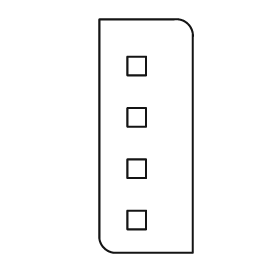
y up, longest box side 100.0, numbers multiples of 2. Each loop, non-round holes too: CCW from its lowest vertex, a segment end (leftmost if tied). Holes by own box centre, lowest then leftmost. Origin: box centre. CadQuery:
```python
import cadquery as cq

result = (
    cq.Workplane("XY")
    .moveTo(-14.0, -50.0)
    .lineTo(20.0, -50.0)
    .lineTo(20.0, 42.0)
    .threePointArc((18.0, 48.0), (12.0, 50.0))
    .lineTo(-20.0, 50.0)
    .lineTo(-20.0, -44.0)
    .threePointArc((-18.0, -48.0), (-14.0, -50.0))
    .close()
    .moveTo(-8.0, -40.0)
    .lineTo(0.0, -40.0)
    .lineTo(0.0, -32.0)
    .lineTo(-8.0, -32.0)
    .close()
    .moveTo(-8.0, -18.0)
    .lineTo(0.0, -18.0)
    .lineTo(0.0, -10.0)
    .lineTo(-8.0, -10.0)
    .close()
    .moveTo(-8.0, 4.0)
    .lineTo(0.0, 4.0)
    .lineTo(0.0, 12.0)
    .lineTo(-8.0, 12.0)
    .close()
    .moveTo(-8.0, 26.0)
    .lineTo(0.0, 26.0)
    .lineTo(0.0, 34.0)
    .lineTo(-8.0, 34.0)
    .close()
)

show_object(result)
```